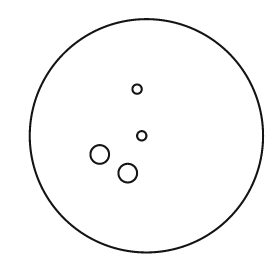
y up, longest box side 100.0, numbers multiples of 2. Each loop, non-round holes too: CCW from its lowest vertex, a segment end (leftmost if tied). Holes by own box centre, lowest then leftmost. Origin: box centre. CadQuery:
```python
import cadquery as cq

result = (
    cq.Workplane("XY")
    .moveTo(0.0, 0.0)
    .circle(50.0)
    .moveTo(-8.0, -16.0)
    .circle(4.0)
    .moveTo(-20.0, -8.0)
    .circle(4.0)
    .moveTo(-2.0, 0.0)
    .circle(2.0)
    .moveTo(-4.0, 20.0)
    .circle(2.0)
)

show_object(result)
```